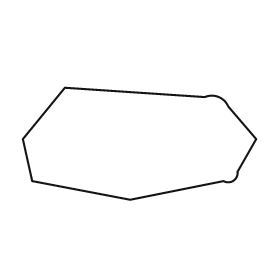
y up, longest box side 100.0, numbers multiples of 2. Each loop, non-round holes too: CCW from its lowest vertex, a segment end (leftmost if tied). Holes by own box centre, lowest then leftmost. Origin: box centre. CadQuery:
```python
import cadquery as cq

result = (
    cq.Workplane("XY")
    .moveTo(-4.0, -24.0)
    .lineTo(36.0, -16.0)
    .threePointArc((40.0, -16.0), (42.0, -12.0))
    .lineTo(50.0, 2.0)
    .lineTo(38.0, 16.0)
    .threePointArc((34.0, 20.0), (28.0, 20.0))
    .lineTo(-32.0, 24.0)
    .lineTo(-50.0, 2.0)
    .lineTo(-46.0, -16.0)
    .close()
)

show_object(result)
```